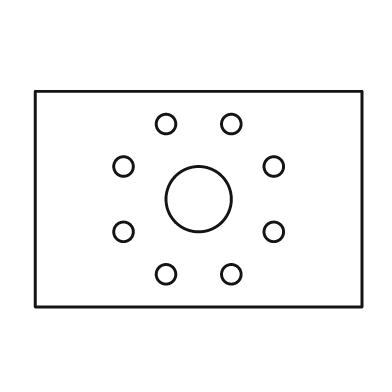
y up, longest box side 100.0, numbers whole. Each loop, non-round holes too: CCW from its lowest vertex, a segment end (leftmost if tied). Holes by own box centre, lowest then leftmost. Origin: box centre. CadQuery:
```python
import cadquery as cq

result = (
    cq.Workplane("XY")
    .moveTo(-50.0, -33.0)
    .lineTo(50.0, -33.0)
    .lineTo(50.0, 33.0)
    .lineTo(-50.0, 33.0)
    .close()
    .moveTo(-10.0, -23.0)
    .circle(3.0)
    .moveTo(10.0, -23.0)
    .circle(3.0)
    .moveTo(-23.0, -10.0)
    .circle(3.0)
    .moveTo(23.0, -10.0)
    .circle(3.0)
    .moveTo(0.0, 0.0)
    .circle(10.0)
    .moveTo(-23.0, 10.0)
    .circle(3.0)
    .moveTo(23.0, 10.0)
    .circle(3.0)
    .moveTo(-10.0, 23.0)
    .circle(3.0)
    .moveTo(10.0, 23.0)
    .circle(3.0)
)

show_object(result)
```